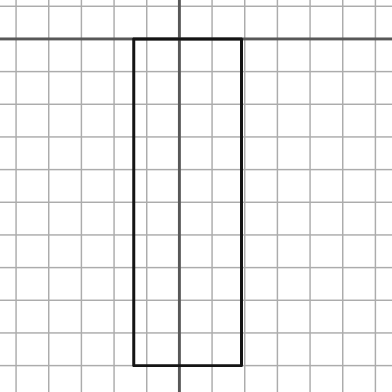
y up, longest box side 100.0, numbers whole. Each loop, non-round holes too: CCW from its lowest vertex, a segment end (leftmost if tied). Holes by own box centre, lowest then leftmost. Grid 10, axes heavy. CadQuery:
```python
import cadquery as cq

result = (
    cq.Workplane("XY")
    .moveTo(-14.0, -100.0)
    .lineTo(19.0, -100.0)
    .lineTo(19.0, 0.0)
    .lineTo(-14.0, 0.0)
    .close()
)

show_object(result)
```